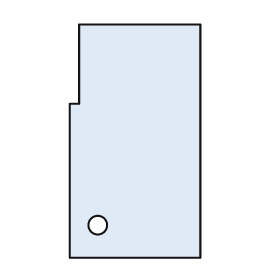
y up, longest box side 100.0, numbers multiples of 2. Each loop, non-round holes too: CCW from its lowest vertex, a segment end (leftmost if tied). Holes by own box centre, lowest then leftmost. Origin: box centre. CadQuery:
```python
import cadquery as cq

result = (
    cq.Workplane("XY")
    .moveTo(-28.0, -50.0)
    .lineTo(28.0, -50.0)
    .lineTo(28.0, 50.0)
    .lineTo(-24.0, 50.0)
    .lineTo(-24.0, 16.0)
    .lineTo(-28.0, 16.0)
    .close()
    .moveTo(-16.0, -36.0)
    .circle(4.0)
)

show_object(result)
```